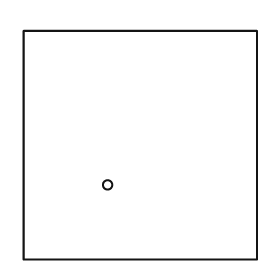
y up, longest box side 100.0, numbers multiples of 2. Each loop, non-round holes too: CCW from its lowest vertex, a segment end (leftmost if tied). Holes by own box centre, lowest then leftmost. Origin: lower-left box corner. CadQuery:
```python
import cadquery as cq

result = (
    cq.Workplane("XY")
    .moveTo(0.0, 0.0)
    .lineTo(100.0, 0.0)
    .lineTo(100.0, 98.0)
    .lineTo(0.0, 98.0)
    .close()
    .moveTo(36.0, 32.0)
    .circle(2.0)
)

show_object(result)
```